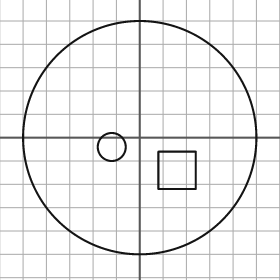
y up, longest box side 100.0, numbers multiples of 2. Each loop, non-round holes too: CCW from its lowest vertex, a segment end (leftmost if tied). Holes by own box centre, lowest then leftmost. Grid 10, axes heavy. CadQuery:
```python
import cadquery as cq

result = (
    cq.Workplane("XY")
    .moveTo(0.0, 0.0)
    .circle(50.0)
    .moveTo(8.0, -22.0)
    .lineTo(24.0, -22.0)
    .lineTo(24.0, -6.0)
    .lineTo(8.0, -6.0)
    .close()
    .moveTo(-12.0, -4.0)
    .circle(6.0)
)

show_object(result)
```